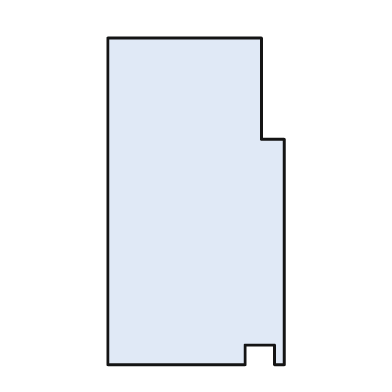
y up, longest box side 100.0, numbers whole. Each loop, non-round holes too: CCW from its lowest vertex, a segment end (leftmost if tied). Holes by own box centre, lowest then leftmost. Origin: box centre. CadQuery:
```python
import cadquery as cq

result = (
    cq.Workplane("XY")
    .moveTo(-27.0, -50.0)
    .lineTo(15.0, -50.0)
    .lineTo(15.0, -44.0)
    .lineTo(24.0, -44.0)
    .lineTo(24.0, -50.0)
    .lineTo(27.0, -50.0)
    .lineTo(27.0, 19.0)
    .lineTo(20.0, 19.0)
    .lineTo(20.0, 50.0)
    .lineTo(-27.0, 50.0)
    .close()
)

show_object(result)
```